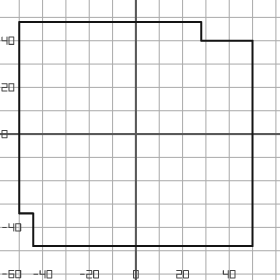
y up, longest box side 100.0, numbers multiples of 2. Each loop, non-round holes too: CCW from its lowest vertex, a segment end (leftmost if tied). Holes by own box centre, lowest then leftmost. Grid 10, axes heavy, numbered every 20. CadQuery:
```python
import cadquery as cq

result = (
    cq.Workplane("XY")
    .moveTo(-44.0, -48.0)
    .lineTo(50.0, -48.0)
    .lineTo(50.0, 40.0)
    .lineTo(28.0, 40.0)
    .lineTo(28.0, 48.0)
    .lineTo(-50.0, 48.0)
    .lineTo(-50.0, -34.0)
    .lineTo(-44.0, -34.0)
    .close()
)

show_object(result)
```